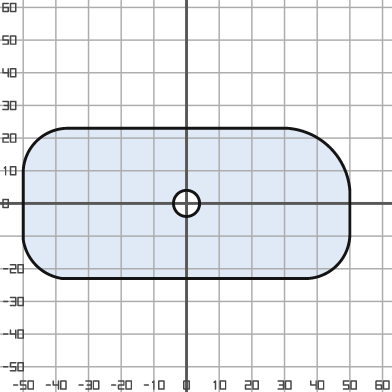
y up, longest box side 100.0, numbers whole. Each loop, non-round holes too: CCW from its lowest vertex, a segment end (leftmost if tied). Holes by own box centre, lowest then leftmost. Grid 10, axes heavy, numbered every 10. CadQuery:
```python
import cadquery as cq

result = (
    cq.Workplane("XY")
    .moveTo(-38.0, -23.0)
    .lineTo(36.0, -23.0)
    .threePointArc((46.0, -19.0), (50.0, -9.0))
    .lineTo(50.0, 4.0)
    .threePointArc((44.0, 17.0), (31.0, 23.0))
    .lineTo(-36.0, 23.0)
    .threePointArc((-46.0, 19.0), (-50.0, 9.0))
    .lineTo(-50.0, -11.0)
    .threePointArc((-46.0, -19.0), (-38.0, -23.0))
    .close()
    .moveTo(0.0, 0.0)
    .circle(4.0)
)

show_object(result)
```